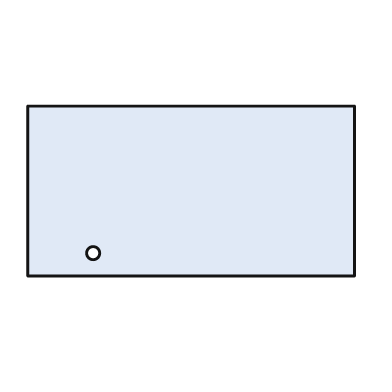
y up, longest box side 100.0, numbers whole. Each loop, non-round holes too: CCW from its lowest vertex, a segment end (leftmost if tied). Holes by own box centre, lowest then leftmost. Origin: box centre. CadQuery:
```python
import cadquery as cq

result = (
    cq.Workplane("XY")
    .moveTo(-50.0, -26.0)
    .lineTo(50.0, -26.0)
    .lineTo(50.0, 26.0)
    .lineTo(-50.0, 26.0)
    .close()
    .moveTo(-30.0, -19.0)
    .circle(2.0)
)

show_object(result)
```